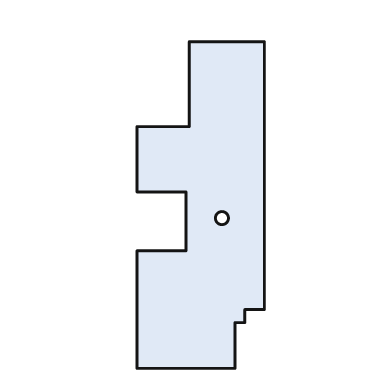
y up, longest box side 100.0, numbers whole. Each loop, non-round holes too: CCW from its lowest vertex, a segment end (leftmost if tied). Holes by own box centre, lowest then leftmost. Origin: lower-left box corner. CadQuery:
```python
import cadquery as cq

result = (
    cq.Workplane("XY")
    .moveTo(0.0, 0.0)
    .lineTo(30.0, 0.0)
    .lineTo(30.0, 14.0)
    .lineTo(33.0, 14.0)
    .lineTo(33.0, 18.0)
    .lineTo(39.0, 18.0)
    .lineTo(39.0, 100.0)
    .lineTo(16.0, 100.0)
    .lineTo(16.0, 74.0)
    .lineTo(0.0, 74.0)
    .lineTo(0.0, 54.0)
    .lineTo(15.0, 54.0)
    .lineTo(15.0, 36.0)
    .lineTo(0.0, 36.0)
    .close()
    .moveTo(26.0, 46.0)
    .circle(2.0)
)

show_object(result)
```